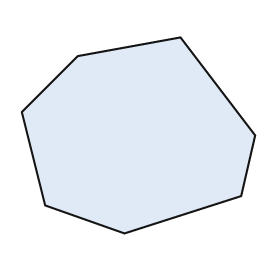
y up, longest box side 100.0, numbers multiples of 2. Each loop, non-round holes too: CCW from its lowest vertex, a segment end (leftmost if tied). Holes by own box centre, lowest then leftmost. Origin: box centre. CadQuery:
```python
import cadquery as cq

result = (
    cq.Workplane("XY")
    .moveTo(-6.0, -42.0)
    .lineTo(44.0, -26.0)
    .lineTo(50.0, 0.0)
    .lineTo(18.0, 42.0)
    .lineTo(-26.0, 34.0)
    .lineTo(-50.0, 10.0)
    .lineTo(-40.0, -30.0)
    .close()
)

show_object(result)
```